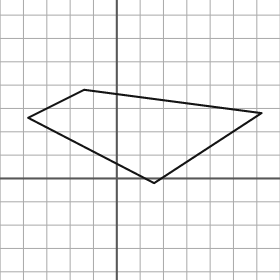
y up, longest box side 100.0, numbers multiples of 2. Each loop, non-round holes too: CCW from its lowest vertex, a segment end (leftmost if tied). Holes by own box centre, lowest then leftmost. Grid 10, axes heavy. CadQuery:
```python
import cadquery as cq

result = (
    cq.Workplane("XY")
    .moveTo(16.0, -2.0)
    .lineTo(62.0, 28.0)
    .lineTo(-14.0, 38.0)
    .lineTo(-38.0, 26.0)
    .close()
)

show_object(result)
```